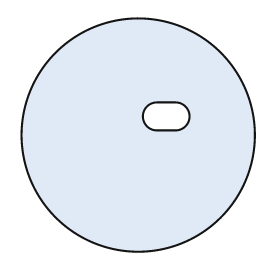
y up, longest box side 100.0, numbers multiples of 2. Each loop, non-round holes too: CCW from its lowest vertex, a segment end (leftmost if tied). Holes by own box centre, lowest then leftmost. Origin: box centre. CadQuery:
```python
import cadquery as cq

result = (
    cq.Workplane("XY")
    .moveTo(0.0, 0.0)
    .circle(50.0)
    .moveTo(8.0, 2.0)
    .lineTo(16.0, 2.0)
    .threePointArc((22.0, 8.0), (16.0, 14.0))
    .lineTo(8.0, 14.0)
    .threePointArc((2.0, 8.0), (8.0, 2.0))
    .close()
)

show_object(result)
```